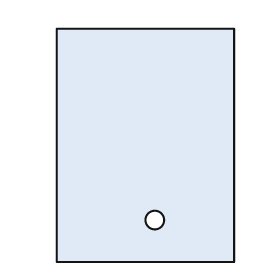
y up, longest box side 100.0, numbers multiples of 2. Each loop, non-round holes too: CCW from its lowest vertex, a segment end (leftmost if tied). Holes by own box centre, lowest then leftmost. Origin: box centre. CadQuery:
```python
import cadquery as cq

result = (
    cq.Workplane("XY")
    .moveTo(-38.0, -50.0)
    .lineTo(38.0, -50.0)
    .lineTo(38.0, 50.0)
    .lineTo(-38.0, 50.0)
    .close()
    .moveTo(4.0, -32.0)
    .circle(4.0)
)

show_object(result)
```